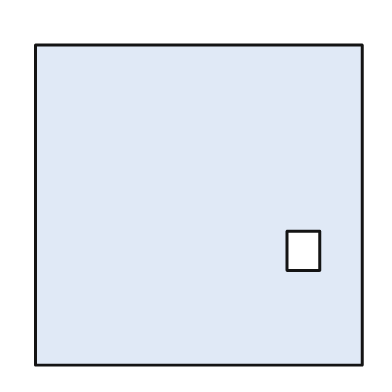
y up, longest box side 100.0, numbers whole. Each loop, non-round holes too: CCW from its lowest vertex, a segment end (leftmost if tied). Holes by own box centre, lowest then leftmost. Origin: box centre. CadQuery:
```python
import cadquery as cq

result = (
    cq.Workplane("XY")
    .moveTo(-50.0, -49.0)
    .lineTo(50.0, -49.0)
    .lineTo(50.0, 49.0)
    .lineTo(-50.0, 49.0)
    .close()
    .moveTo(27.0, -20.0)
    .lineTo(37.0, -20.0)
    .lineTo(37.0, -8.0)
    .lineTo(27.0, -8.0)
    .close()
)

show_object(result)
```